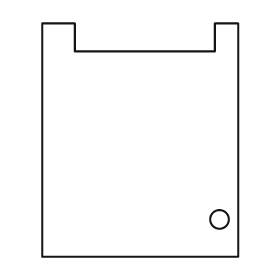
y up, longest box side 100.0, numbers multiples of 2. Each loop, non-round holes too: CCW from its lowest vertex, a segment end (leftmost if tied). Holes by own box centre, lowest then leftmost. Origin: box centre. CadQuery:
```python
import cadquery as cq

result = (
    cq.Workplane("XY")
    .moveTo(-42.0, -50.0)
    .lineTo(42.0, -50.0)
    .lineTo(42.0, 50.0)
    .lineTo(32.0, 50.0)
    .lineTo(32.0, 38.0)
    .lineTo(-28.0, 38.0)
    .lineTo(-28.0, 50.0)
    .lineTo(-42.0, 50.0)
    .close()
    .moveTo(34.0, -34.0)
    .circle(4.0)
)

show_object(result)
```